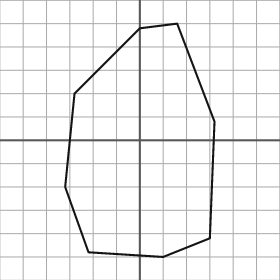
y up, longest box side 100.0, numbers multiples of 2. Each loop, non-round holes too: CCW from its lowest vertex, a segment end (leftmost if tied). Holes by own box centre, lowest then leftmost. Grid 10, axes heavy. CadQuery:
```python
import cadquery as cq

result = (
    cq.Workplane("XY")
    .moveTo(10.0, -50.0)
    .lineTo(30.0, -42.0)
    .lineTo(32.0, 8.0)
    .lineTo(16.0, 50.0)
    .lineTo(0.0, 48.0)
    .lineTo(-28.0, 20.0)
    .lineTo(-32.0, -20.0)
    .lineTo(-22.0, -48.0)
    .close()
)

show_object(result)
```